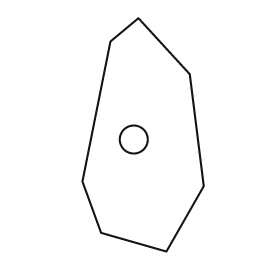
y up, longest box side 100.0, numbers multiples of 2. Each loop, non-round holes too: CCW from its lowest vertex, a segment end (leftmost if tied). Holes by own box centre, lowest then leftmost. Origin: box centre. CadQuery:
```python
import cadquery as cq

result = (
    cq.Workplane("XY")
    .moveTo(10.0, -50.0)
    .lineTo(26.0, -22.0)
    .lineTo(20.0, 26.0)
    .lineTo(-2.0, 50.0)
    .lineTo(-14.0, 40.0)
    .lineTo(-26.0, -20.0)
    .lineTo(-18.0, -42.0)
    .close()
    .moveTo(-4.0, -2.0)
    .circle(6.0)
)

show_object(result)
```